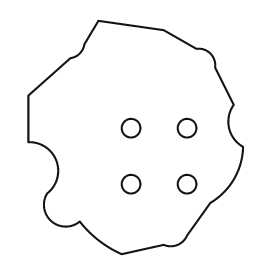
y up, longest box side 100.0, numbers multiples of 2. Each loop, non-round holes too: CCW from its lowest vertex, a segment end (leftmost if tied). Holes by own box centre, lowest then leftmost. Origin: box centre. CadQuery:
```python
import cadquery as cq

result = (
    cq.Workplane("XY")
    .moveTo(-6.0, -50.0)
    .lineTo(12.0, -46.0)
    .threePointArc((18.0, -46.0), (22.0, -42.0))
    .lineTo(32.0, -28.0)
    .threePointArc((42.0, -18.0), (46.0, -4.0))
    .threePointArc((40.0, 4.0), (42.0, 14.0))
    .lineTo(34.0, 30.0)
    .threePointArc((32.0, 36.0), (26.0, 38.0))
    .lineTo(12.0, 46.0)
    .lineTo(-16.0, 50.0)
    .lineTo(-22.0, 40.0)
    .threePointArc((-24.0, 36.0), (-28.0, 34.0))
    .lineTo(-46.0, 18.0)
    .lineTo(-46.0, -2.0)
    .threePointArc((-34.0, -10.0), (-38.0, -24.0))
    .threePointArc((-36.0, -36.0), (-24.0, -36.0))
    .threePointArc((-16.0, -44.0), (-6.0, -50.0))
    .close()
    .moveTo(-2.0, -20.0)
    .circle(4.0)
    .moveTo(22.0, -20.0)
    .circle(4.0)
    .moveTo(-2.0, 4.0)
    .circle(4.0)
    .moveTo(22.0, 4.0)
    .circle(4.0)
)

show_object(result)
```